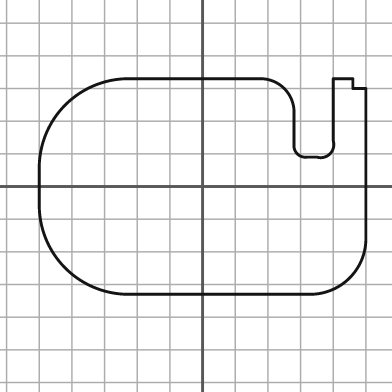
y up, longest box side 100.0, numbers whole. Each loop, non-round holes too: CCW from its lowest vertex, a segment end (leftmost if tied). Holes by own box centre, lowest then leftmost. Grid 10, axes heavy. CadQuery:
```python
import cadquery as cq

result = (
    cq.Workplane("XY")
    .moveTo(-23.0, -33.0)
    .lineTo(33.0, -33.0)
    .threePointArc((45.0, -28.0), (50.0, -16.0))
    .lineTo(50.0, 30.0)
    .lineTo(46.0, 30.0)
    .lineTo(46.0, 33.0)
    .lineTo(40.0, 33.0)
    .lineTo(40.0, 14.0)
    .threePointArc((39.0, 10.0), (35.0, 9.0))
    .lineTo(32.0, 9.0)
    .threePointArc((29.0, 10.0), (28.0, 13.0))
    .lineTo(28.0, 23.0)
    .threePointArc((25.0, 30.0), (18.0, 33.0))
    .lineTo(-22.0, 33.0)
    .threePointArc((-42.0, 25.0), (-50.0, 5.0))
    .lineTo(-50.0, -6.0)
    .threePointArc((-42.0, -25.0), (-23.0, -33.0))
    .close()
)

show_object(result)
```